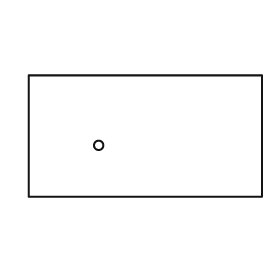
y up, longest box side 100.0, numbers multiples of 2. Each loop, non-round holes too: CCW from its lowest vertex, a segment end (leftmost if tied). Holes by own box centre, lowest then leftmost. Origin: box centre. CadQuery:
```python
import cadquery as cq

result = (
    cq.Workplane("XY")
    .moveTo(-50.0, -26.0)
    .lineTo(50.0, -26.0)
    .lineTo(50.0, 26.0)
    .lineTo(-50.0, 26.0)
    .close()
    .moveTo(-20.0, -4.0)
    .circle(2.0)
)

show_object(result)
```